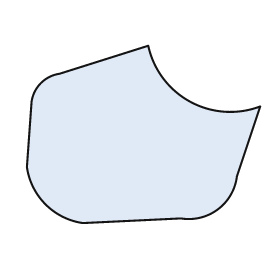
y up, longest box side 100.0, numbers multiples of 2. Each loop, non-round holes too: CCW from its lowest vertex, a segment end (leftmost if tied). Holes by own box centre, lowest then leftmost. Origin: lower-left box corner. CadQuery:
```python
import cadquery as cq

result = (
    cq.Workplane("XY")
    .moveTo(24.0, 0.0)
    .lineTo(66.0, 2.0)
    .threePointArc((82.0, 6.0), (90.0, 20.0))
    .lineTo(100.0, 50.0)
    .threePointArc((70.0, 52.0), (52.0, 76.0))
    .lineTo(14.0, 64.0)
    .threePointArc((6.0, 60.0), (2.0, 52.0))
    .lineTo(0.0, 24.0)
    .threePointArc((8.0, 8.0), (24.0, 0.0))
    .close()
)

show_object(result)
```